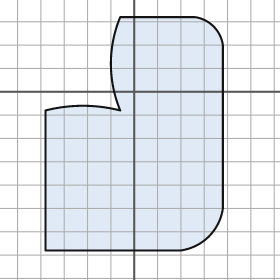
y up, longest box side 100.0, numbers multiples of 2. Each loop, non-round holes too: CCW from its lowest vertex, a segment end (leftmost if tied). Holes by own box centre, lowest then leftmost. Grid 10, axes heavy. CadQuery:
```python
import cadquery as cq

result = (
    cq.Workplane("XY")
    .moveTo(-38.0, -68.0)
    .lineTo(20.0, -68.0)
    .threePointArc((32.0, -62.0), (38.0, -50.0))
    .lineTo(38.0, 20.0)
    .threePointArc((34.0, 28.0), (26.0, 32.0))
    .lineTo(-6.0, 32.0)
    .threePointArc((-10.0, 12.0), (-6.0, -8.0))
    .threePointArc((-22.0, -6.0), (-38.0, -8.0))
    .close()
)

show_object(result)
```